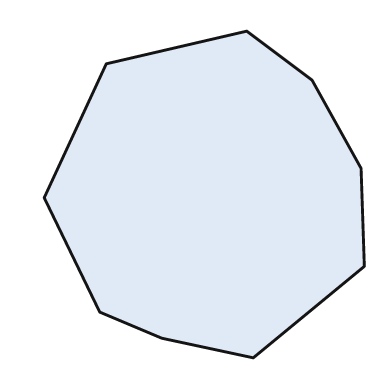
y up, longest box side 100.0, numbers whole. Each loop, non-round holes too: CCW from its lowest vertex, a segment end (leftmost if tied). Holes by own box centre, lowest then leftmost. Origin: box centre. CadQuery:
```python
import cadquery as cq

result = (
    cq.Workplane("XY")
    .moveTo(15.0, -50.0)
    .lineTo(49.0, -22.0)
    .lineTo(48.0, 8.0)
    .lineTo(33.0, 35.0)
    .lineTo(13.0, 50.0)
    .lineTo(-30.0, 40.0)
    .lineTo(-49.0, -1.0)
    .lineTo(-32.0, -36.0)
    .lineTo(-13.0, -44.0)
    .close()
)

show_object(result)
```